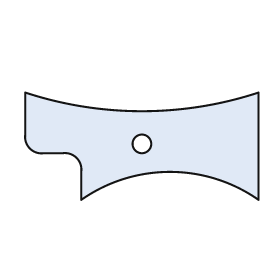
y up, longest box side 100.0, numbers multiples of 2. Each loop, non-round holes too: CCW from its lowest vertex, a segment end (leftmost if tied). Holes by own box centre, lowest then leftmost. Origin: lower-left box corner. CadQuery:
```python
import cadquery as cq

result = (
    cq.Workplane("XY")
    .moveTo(24.0, 0.0)
    .threePointArc((62.0, 12.0), (100.0, 0.0))
    .lineTo(100.0, 46.0)
    .threePointArc((50.0, 38.0), (0.0, 46.0))
    .lineTo(0.0, 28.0)
    .threePointArc((2.0, 22.0), (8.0, 20.0))
    .lineTo(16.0, 20.0)
    .threePointArc((22.0, 18.0), (24.0, 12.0))
    .close()
    .moveTo(50.0, 24.0)
    .circle(4.0)
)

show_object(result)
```